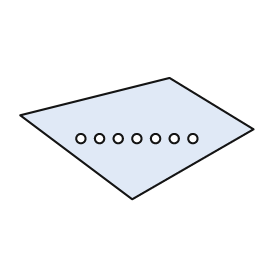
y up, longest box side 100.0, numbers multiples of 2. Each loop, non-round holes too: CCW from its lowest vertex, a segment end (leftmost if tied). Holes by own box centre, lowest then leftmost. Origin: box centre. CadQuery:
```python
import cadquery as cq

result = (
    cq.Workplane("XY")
    .moveTo(-2.0, -26.0)
    .lineTo(50.0, 4.0)
    .lineTo(14.0, 26.0)
    .lineTo(-50.0, 10.0)
    .close()
    .moveTo(-24.0, 0.0)
    .circle(2.0)
    .moveTo(-16.0, 0.0)
    .circle(2.0)
    .moveTo(-8.0, 0.0)
    .circle(2.0)
    .moveTo(0.0, 0.0)
    .circle(2.0)
    .moveTo(8.0, 0.0)
    .circle(2.0)
    .moveTo(16.0, 0.0)
    .circle(2.0)
    .moveTo(24.0, 0.0)
    .circle(2.0)
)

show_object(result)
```